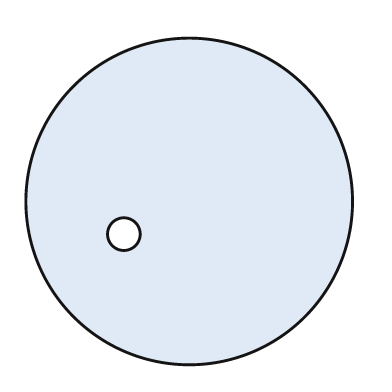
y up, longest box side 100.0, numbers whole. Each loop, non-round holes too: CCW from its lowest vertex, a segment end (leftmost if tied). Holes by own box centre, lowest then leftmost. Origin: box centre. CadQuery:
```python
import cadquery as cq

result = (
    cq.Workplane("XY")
    .moveTo(0.0, 0.0)
    .circle(50.0)
    .moveTo(-20.0, -10.0)
    .circle(5.0)
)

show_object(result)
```